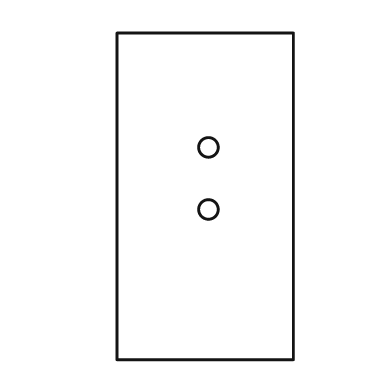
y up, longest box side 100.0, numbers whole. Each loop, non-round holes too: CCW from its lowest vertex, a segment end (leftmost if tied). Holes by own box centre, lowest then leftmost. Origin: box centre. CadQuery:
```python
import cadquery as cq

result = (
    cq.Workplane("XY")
    .moveTo(-27.0, -50.0)
    .lineTo(27.0, -50.0)
    .lineTo(27.0, 50.0)
    .lineTo(-27.0, 50.0)
    .close()
    .moveTo(1.0, -4.0)
    .circle(3.0)
    .moveTo(1.0, 15.0)
    .circle(3.0)
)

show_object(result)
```